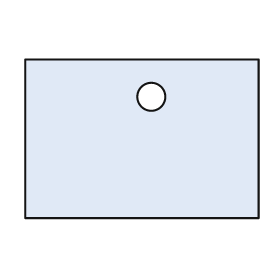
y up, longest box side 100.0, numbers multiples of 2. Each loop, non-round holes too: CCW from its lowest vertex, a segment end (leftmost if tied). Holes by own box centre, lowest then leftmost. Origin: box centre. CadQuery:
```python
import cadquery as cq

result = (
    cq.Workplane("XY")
    .moveTo(-50.0, -34.0)
    .lineTo(50.0, -34.0)
    .lineTo(50.0, 34.0)
    .lineTo(-50.0, 34.0)
    .close()
    .moveTo(4.0, 18.0)
    .circle(6.0)
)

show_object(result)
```